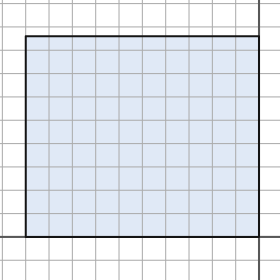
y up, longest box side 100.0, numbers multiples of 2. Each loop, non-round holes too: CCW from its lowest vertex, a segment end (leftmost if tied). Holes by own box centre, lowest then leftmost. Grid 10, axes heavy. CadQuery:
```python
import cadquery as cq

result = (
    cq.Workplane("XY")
    .moveTo(-100.0, 0.0)
    .lineTo(0.0, 0.0)
    .lineTo(0.0, 86.0)
    .lineTo(-100.0, 86.0)
    .close()
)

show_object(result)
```